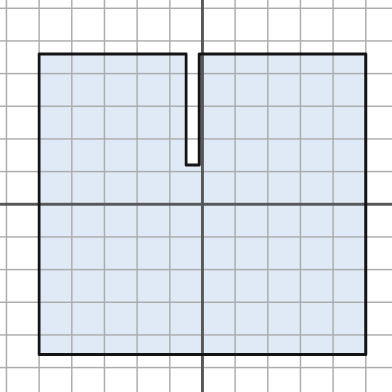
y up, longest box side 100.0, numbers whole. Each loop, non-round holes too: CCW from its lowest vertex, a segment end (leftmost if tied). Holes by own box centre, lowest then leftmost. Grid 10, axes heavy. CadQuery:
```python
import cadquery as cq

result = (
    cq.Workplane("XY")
    .moveTo(-50.0, -46.0)
    .lineTo(50.0, -46.0)
    .lineTo(50.0, 46.0)
    .lineTo(-1.0, 46.0)
    .lineTo(-1.0, 12.0)
    .lineTo(-5.0, 12.0)
    .lineTo(-5.0, 46.0)
    .lineTo(-50.0, 46.0)
    .close()
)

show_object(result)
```